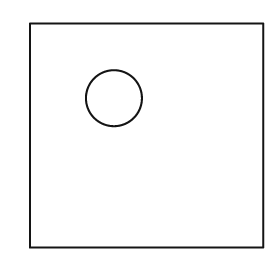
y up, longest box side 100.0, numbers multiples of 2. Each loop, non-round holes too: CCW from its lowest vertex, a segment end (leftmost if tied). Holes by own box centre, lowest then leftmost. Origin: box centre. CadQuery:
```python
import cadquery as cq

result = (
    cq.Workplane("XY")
    .moveTo(-50.0, -48.0)
    .lineTo(50.0, -48.0)
    .lineTo(50.0, 48.0)
    .lineTo(-50.0, 48.0)
    .close()
    .moveTo(-14.0, 16.0)
    .circle(12.0)
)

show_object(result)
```